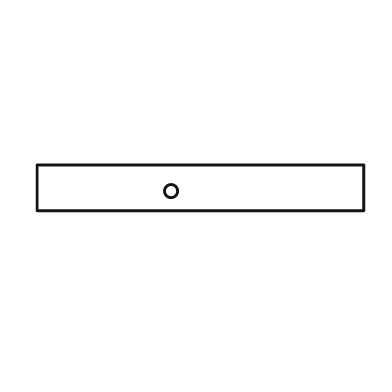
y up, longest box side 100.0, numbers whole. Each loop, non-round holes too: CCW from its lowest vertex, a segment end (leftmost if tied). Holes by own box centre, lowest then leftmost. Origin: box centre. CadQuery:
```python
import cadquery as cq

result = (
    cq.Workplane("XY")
    .moveTo(-50.0, -7.0)
    .lineTo(50.0, -7.0)
    .lineTo(50.0, 7.0)
    .lineTo(-50.0, 7.0)
    .close()
    .moveTo(-9.0, -1.0)
    .circle(2.0)
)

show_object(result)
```